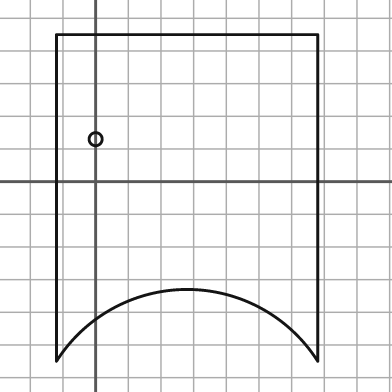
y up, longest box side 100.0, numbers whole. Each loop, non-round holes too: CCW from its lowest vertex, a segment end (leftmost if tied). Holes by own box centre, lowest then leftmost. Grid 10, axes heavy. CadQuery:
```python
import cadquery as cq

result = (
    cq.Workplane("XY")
    .moveTo(-12.0, -55.0)
    .threePointArc((28.0, -33.0), (68.0, -55.0))
    .lineTo(68.0, 45.0)
    .lineTo(-12.0, 45.0)
    .close()
    .moveTo(0.0, 13.0)
    .circle(2.0)
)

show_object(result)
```